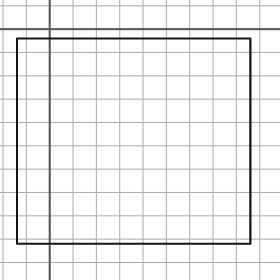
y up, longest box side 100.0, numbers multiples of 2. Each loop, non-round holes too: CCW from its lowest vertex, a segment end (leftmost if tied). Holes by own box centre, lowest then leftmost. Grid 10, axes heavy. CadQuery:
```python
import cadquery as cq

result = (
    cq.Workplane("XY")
    .moveTo(-14.0, -92.0)
    .lineTo(86.0, -92.0)
    .lineTo(86.0, -4.0)
    .lineTo(-14.0, -4.0)
    .close()
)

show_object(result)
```